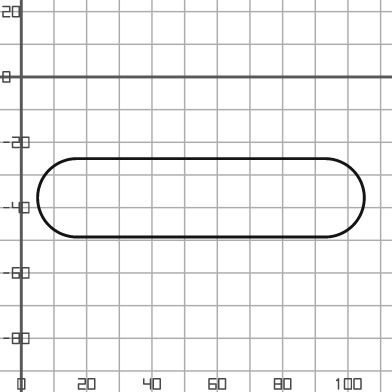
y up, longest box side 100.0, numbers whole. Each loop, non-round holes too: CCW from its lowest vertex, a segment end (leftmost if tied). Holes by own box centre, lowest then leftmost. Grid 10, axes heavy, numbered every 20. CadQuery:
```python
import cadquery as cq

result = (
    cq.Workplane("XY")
    .moveTo(17.0, -49.0)
    .lineTo(93.0, -49.0)
    .threePointArc((105.0, -37.0), (93.0, -25.0))
    .lineTo(17.0, -25.0)
    .threePointArc((5.0, -37.0), (17.0, -49.0))
    .close()
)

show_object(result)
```